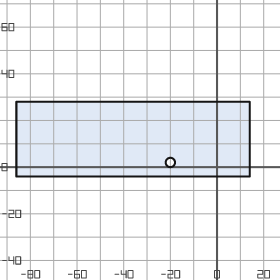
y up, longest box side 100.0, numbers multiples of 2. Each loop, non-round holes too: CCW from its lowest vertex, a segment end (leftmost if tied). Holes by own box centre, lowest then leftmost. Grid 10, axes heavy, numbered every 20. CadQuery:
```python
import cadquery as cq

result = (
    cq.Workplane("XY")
    .moveTo(-86.0, -4.0)
    .lineTo(14.0, -4.0)
    .lineTo(14.0, 28.0)
    .lineTo(-86.0, 28.0)
    .close()
    .moveTo(-20.0, 2.0)
    .circle(2.0)
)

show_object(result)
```